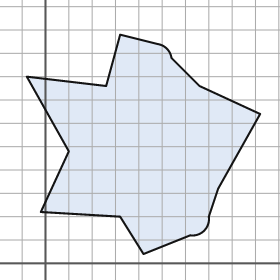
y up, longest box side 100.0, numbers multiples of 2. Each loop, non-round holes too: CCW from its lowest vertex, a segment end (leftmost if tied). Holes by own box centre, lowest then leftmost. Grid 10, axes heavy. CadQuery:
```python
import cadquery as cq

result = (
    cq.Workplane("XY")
    .moveTo(42.0, 4.0)
    .lineTo(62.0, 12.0)
    .threePointArc((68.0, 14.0), (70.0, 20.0))
    .lineTo(74.0, 32.0)
    .lineTo(92.0, 64.0)
    .lineTo(66.0, 76.0)
    .lineTo(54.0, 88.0)
    .threePointArc((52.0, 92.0), (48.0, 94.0))
    .lineTo(32.0, 98.0)
    .lineTo(26.0, 76.0)
    .lineTo(-8.0, 80.0)
    .lineTo(10.0, 48.0)
    .lineTo(-2.0, 22.0)
    .lineTo(32.0, 20.0)
    .close()
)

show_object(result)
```